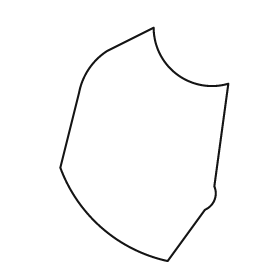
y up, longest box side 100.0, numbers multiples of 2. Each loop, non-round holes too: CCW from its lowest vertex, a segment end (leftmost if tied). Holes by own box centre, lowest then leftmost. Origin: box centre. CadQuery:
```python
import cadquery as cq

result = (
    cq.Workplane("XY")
    .moveTo(10.0, -50.0)
    .lineTo(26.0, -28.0)
    .threePointArc((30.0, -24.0), (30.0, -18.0))
    .lineTo(36.0, 26.0)
    .threePointArc((14.0, 30.0), (4.0, 50.0))
    .lineTo(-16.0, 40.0)
    .threePointArc((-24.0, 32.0), (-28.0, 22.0))
    .lineTo(-36.0, -10.0)
    .threePointArc((-18.0, -36.0), (10.0, -50.0))
    .close()
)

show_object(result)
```